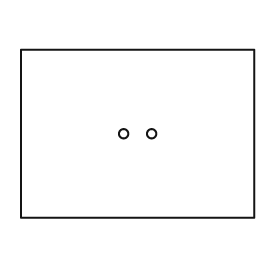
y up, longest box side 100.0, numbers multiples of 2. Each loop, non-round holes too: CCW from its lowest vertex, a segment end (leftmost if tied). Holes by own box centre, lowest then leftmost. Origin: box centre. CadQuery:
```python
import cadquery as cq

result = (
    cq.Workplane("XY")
    .moveTo(-50.0, -36.0)
    .lineTo(50.0, -36.0)
    .lineTo(50.0, 36.0)
    .lineTo(-50.0, 36.0)
    .close()
    .moveTo(-6.0, 0.0)
    .circle(2.0)
    .moveTo(6.0, 0.0)
    .circle(2.0)
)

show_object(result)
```